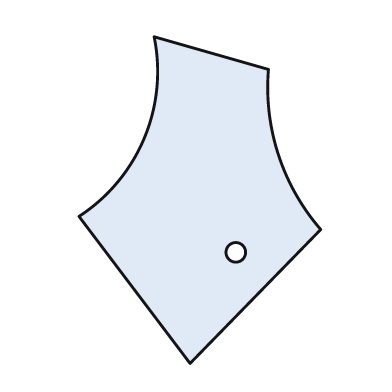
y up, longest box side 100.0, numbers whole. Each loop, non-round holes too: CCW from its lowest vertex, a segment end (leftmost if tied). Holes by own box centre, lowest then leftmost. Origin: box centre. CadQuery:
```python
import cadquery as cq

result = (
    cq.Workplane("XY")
    .moveTo(-3.0, -50.0)
    .lineTo(37.0, -9.0)
    .threePointArc((24.0, 14.0), (21.0, 40.0))
    .lineTo(-14.0, 50.0)
    .threePointArc((-17.0, 19.0), (-37.0, -5.0))
    .close()
    .moveTo(11.0, -16.0)
    .circle(3.0)
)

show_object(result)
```